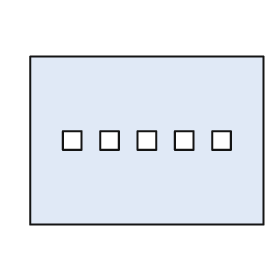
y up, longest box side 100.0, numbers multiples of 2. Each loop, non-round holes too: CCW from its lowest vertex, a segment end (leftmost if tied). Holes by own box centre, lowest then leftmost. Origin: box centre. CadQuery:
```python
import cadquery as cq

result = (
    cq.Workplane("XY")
    .moveTo(-50.0, -36.0)
    .lineTo(50.0, -36.0)
    .lineTo(50.0, 36.0)
    .lineTo(-50.0, 36.0)
    .close()
    .moveTo(-36.0, -4.0)
    .lineTo(-28.0, -4.0)
    .lineTo(-28.0, 4.0)
    .lineTo(-36.0, 4.0)
    .close()
    .moveTo(-20.0, -4.0)
    .lineTo(-12.0, -4.0)
    .lineTo(-12.0, 4.0)
    .lineTo(-20.0, 4.0)
    .close()
    .moveTo(-4.0, -4.0)
    .lineTo(4.0, -4.0)
    .lineTo(4.0, 4.0)
    .lineTo(-4.0, 4.0)
    .close()
    .moveTo(12.0, -4.0)
    .lineTo(20.0, -4.0)
    .lineTo(20.0, 4.0)
    .lineTo(12.0, 4.0)
    .close()
    .moveTo(28.0, -4.0)
    .lineTo(36.0, -4.0)
    .lineTo(36.0, 4.0)
    .lineTo(28.0, 4.0)
    .close()
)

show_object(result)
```